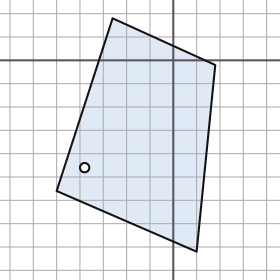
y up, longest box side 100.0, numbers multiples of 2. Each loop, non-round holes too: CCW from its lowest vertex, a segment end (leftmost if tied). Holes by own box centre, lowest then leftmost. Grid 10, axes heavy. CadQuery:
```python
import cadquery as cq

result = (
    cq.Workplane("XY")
    .moveTo(10.0, -82.0)
    .lineTo(18.0, -2.0)
    .lineTo(-26.0, 18.0)
    .lineTo(-50.0, -56.0)
    .close()
    .moveTo(-38.0, -46.0)
    .circle(2.0)
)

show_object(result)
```